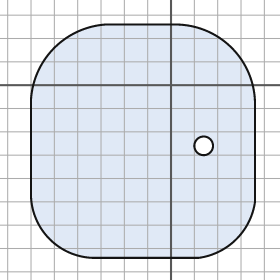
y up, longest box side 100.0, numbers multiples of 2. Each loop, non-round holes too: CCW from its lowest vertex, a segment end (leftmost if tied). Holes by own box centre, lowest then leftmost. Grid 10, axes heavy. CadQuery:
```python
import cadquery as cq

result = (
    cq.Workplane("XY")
    .moveTo(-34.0, -74.0)
    .lineTo(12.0, -74.0)
    .threePointArc((28.0, -66.0), (36.0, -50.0))
    .lineTo(36.0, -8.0)
    .threePointArc((26.0, 16.0), (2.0, 26.0))
    .lineTo(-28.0, 26.0)
    .threePointArc((-50.0, 16.0), (-60.0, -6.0))
    .lineTo(-60.0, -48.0)
    .threePointArc((-52.0, -66.0), (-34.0, -74.0))
    .close()
    .moveTo(14.0, -26.0)
    .circle(4.0)
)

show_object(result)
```